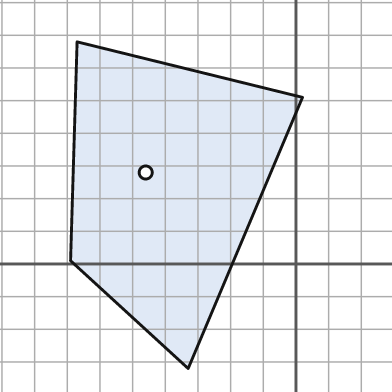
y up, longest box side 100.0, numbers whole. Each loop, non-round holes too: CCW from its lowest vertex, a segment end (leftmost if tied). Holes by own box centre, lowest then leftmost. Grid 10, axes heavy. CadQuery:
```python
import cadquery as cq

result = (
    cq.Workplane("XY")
    .moveTo(-33.0, -32.0)
    .lineTo(2.0, 51.0)
    .lineTo(-67.0, 68.0)
    .lineTo(-69.0, 1.0)
    .close()
    .moveTo(-46.0, 28.0)
    .circle(2.0)
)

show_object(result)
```